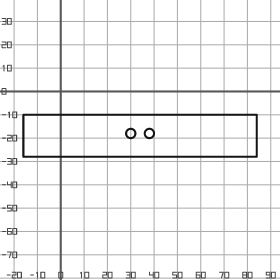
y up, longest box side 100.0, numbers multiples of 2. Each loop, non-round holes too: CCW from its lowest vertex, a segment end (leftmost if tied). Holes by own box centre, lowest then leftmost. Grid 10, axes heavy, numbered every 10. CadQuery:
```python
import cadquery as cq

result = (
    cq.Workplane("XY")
    .moveTo(-16.0, -28.0)
    .lineTo(84.0, -28.0)
    .lineTo(84.0, -10.0)
    .lineTo(-16.0, -10.0)
    .close()
    .moveTo(30.0, -18.0)
    .circle(2.0)
    .moveTo(38.0, -18.0)
    .circle(2.0)
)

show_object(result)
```